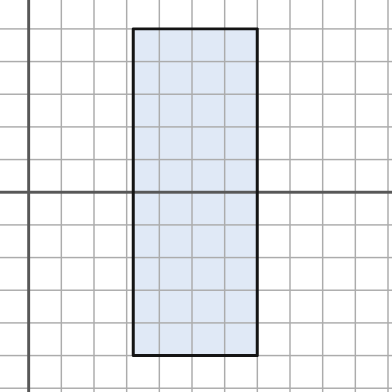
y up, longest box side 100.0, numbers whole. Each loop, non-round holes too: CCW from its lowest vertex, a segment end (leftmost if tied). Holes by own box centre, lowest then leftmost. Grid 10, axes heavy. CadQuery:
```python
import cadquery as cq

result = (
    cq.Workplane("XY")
    .moveTo(32.0, -50.0)
    .lineTo(70.0, -50.0)
    .lineTo(70.0, 50.0)
    .lineTo(32.0, 50.0)
    .close()
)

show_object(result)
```